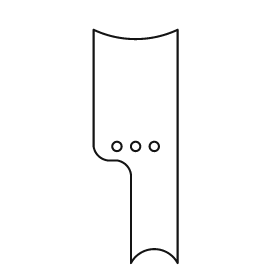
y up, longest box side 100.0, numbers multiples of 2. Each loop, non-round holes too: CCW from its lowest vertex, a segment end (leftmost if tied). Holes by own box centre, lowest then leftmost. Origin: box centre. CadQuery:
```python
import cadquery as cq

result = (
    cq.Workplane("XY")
    .moveTo(-2.0, -50.0)
    .threePointArc((8.0, -44.0), (18.0, -50.0))
    .lineTo(18.0, 50.0)
    .threePointArc((0.0, 46.0), (-18.0, 50.0))
    .lineTo(-18.0, 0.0)
    .threePointArc((-16.0, -4.0), (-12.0, -6.0))
    .lineTo(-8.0, -6.0)
    .threePointArc((-4.0, -8.0), (-2.0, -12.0))
    .close()
    .moveTo(-8.0, 0.0)
    .circle(2.0)
    .moveTo(0.0, 0.0)
    .circle(2.0)
    .moveTo(8.0, 0.0)
    .circle(2.0)
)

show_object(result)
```